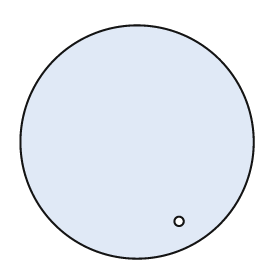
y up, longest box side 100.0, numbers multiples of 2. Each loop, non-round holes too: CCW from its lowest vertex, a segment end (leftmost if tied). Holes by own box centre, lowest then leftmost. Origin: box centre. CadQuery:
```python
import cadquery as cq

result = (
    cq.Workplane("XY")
    .moveTo(0.0, 0.0)
    .circle(50.0)
    .moveTo(18.0, -34.0)
    .circle(2.0)
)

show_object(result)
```